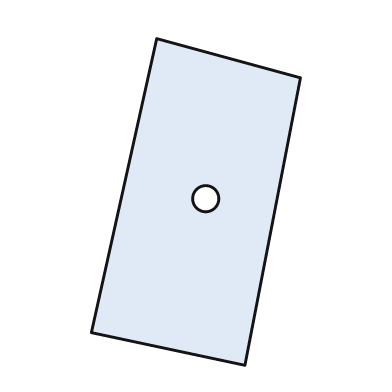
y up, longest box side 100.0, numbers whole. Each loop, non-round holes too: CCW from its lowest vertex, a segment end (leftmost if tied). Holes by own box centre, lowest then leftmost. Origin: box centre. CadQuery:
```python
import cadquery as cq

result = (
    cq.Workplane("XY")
    .moveTo(15.0, -50.0)
    .lineTo(32.0, 38.0)
    .lineTo(-12.0, 50.0)
    .lineTo(-32.0, -40.0)
    .close()
    .moveTo(3.0, 1.0)
    .circle(4.0)
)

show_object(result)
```